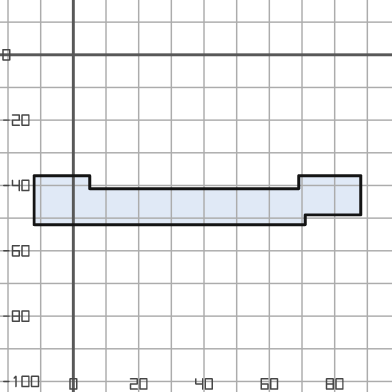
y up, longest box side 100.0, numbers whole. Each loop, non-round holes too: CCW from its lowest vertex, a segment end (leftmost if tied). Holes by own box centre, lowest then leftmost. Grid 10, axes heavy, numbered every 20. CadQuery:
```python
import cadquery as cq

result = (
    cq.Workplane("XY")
    .moveTo(-12.0, -52.0)
    .lineTo(71.0, -52.0)
    .lineTo(71.0, -49.0)
    .lineTo(88.0, -49.0)
    .lineTo(88.0, -37.0)
    .lineTo(69.0, -37.0)
    .lineTo(69.0, -41.0)
    .lineTo(5.0, -41.0)
    .lineTo(5.0, -37.0)
    .lineTo(-12.0, -37.0)
    .close()
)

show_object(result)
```